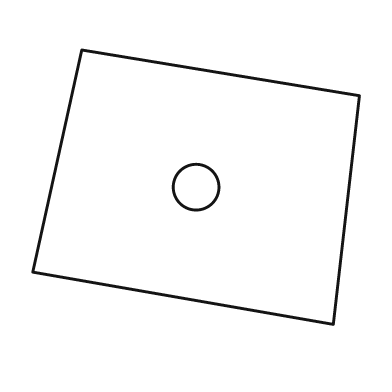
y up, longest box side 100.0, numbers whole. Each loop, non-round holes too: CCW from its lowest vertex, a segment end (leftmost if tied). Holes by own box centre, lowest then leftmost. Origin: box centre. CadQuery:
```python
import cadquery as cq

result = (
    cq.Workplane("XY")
    .moveTo(42.0, -42.0)
    .lineTo(50.0, 28.0)
    .lineTo(-35.0, 42.0)
    .lineTo(-50.0, -26.0)
    .close()
    .moveTo(0.0, 0.0)
    .circle(7.0)
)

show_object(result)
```